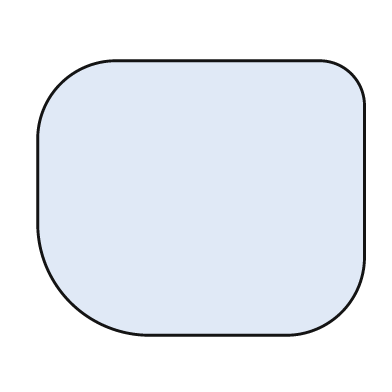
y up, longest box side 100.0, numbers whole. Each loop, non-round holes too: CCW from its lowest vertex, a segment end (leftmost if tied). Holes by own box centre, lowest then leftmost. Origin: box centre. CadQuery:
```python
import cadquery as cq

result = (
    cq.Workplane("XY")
    .moveTo(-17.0, -42.0)
    .lineTo(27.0, -42.0)
    .threePointArc((43.0, -35.0), (50.0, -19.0))
    .lineTo(50.0, 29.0)
    .threePointArc((46.0, 38.0), (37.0, 42.0))
    .lineTo(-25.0, 42.0)
    .threePointArc((-43.0, 35.0), (-50.0, 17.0))
    .lineTo(-50.0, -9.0)
    .threePointArc((-40.0, -32.0), (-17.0, -42.0))
    .close()
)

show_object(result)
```